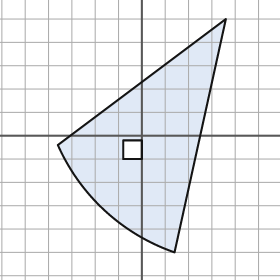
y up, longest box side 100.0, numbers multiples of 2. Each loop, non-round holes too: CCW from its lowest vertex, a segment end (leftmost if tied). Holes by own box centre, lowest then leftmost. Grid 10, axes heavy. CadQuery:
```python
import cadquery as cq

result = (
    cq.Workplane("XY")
    .moveTo(14.0, -50.0)
    .lineTo(36.0, 50.0)
    .lineTo(-36.0, -4.0)
    .threePointArc((-16.0, -32.0), (14.0, -50.0))
    .close()
    .moveTo(-8.0, -10.0)
    .lineTo(0.0, -10.0)
    .lineTo(0.0, -2.0)
    .lineTo(-8.0, -2.0)
    .close()
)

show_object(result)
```